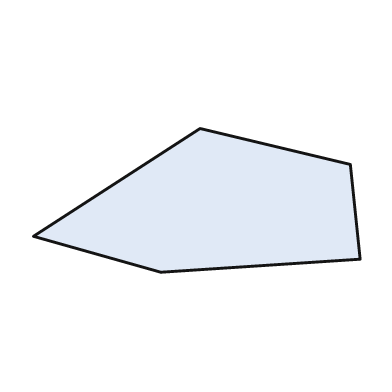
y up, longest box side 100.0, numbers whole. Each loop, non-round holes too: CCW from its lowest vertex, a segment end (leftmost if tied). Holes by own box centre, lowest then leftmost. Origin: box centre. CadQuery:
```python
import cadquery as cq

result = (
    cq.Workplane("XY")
    .moveTo(-11.0, -22.0)
    .lineTo(50.0, -18.0)
    .lineTo(47.0, 11.0)
    .lineTo(1.0, 22.0)
    .lineTo(-50.0, -11.0)
    .close()
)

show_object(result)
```